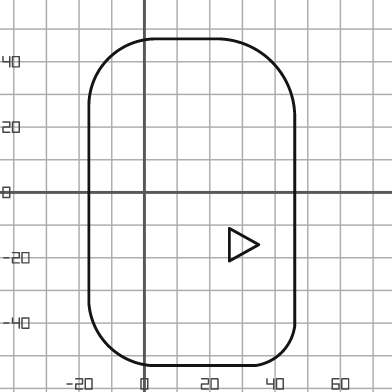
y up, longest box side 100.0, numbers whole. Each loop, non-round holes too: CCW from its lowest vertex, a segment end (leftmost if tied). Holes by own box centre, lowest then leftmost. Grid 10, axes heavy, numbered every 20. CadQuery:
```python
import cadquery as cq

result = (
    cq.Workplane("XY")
    .moveTo(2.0, -53.0)
    .lineTo(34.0, -53.0)
    .threePointArc((42.0, -49.0), (46.0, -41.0))
    .lineTo(46.0, 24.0)
    .threePointArc((39.0, 40.0), (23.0, 47.0))
    .lineTo(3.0, 47.0)
    .threePointArc((-11.0, 41.0), (-17.0, 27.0))
    .lineTo(-17.0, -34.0)
    .threePointArc((-11.0, -47.0), (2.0, -53.0))
    .close()
    .moveTo(26.0, -21.0)
    .lineTo(35.0, -16.0)
    .lineTo(26.0, -11.0)
    .close()
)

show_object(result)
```